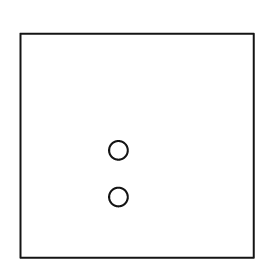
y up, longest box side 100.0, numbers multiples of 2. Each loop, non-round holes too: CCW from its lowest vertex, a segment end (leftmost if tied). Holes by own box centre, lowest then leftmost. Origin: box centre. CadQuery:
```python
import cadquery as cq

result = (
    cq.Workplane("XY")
    .moveTo(-50.0, -48.0)
    .lineTo(50.0, -48.0)
    .lineTo(50.0, 48.0)
    .lineTo(-50.0, 48.0)
    .close()
    .moveTo(-8.0, -22.0)
    .circle(4.0)
    .moveTo(-8.0, -2.0)
    .circle(4.0)
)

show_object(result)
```